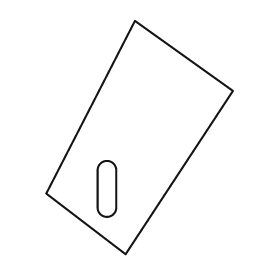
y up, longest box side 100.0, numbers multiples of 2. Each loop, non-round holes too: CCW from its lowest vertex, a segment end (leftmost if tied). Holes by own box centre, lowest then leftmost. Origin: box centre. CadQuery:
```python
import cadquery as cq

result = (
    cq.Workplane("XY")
    .moveTo(-6.0, -50.0)
    .lineTo(40.0, 20.0)
    .lineTo(-2.0, 50.0)
    .lineTo(-40.0, -24.0)
    .close()
    .moveTo(-18.0, -30.0)
    .threePointArc((-14.0, -34.0), (-10.0, -30.0))
    .lineTo(-10.0, -14.0)
    .threePointArc((-14.0, -10.0), (-18.0, -14.0))
    .close()
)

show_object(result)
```